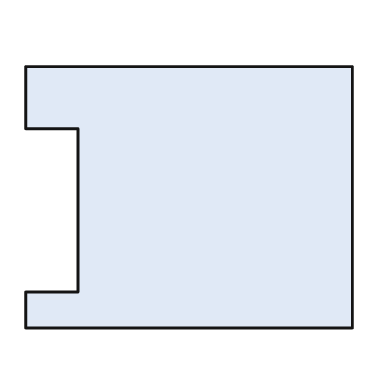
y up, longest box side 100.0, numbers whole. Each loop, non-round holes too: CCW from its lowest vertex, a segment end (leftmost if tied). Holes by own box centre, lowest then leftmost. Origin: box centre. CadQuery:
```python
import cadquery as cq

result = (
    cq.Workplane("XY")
    .moveTo(-50.0, -40.0)
    .lineTo(50.0, -40.0)
    .lineTo(50.0, 40.0)
    .lineTo(-50.0, 40.0)
    .lineTo(-50.0, 21.0)
    .lineTo(-34.0, 21.0)
    .lineTo(-34.0, -29.0)
    .lineTo(-50.0, -29.0)
    .close()
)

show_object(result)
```